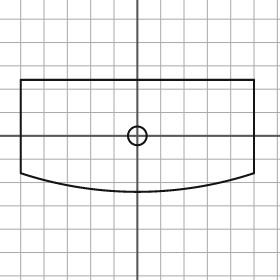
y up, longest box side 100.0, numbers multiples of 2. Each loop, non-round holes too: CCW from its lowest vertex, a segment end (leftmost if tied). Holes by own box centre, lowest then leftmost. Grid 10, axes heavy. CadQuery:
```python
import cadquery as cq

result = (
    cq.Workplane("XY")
    .moveTo(-50.0, -16.0)
    .threePointArc((0.0, -24.0), (50.0, -16.0))
    .lineTo(50.0, 24.0)
    .lineTo(-50.0, 24.0)
    .close()
    .moveTo(0.0, 0.0)
    .circle(4.0)
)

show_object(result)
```